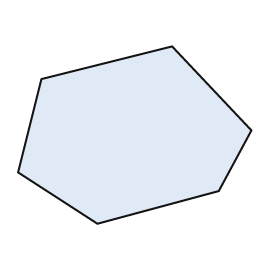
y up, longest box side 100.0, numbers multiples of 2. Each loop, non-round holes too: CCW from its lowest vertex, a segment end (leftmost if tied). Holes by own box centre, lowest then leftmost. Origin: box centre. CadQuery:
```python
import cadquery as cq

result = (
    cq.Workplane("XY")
    .moveTo(-16.0, -38.0)
    .lineTo(36.0, -24.0)
    .lineTo(50.0, 2.0)
    .lineTo(16.0, 38.0)
    .lineTo(-40.0, 24.0)
    .lineTo(-50.0, -16.0)
    .close()
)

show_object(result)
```